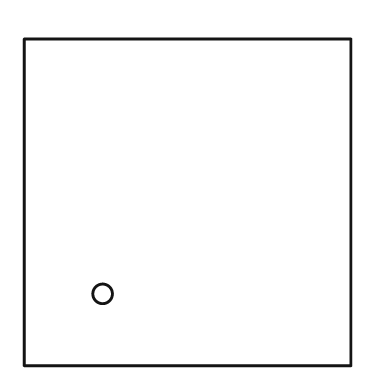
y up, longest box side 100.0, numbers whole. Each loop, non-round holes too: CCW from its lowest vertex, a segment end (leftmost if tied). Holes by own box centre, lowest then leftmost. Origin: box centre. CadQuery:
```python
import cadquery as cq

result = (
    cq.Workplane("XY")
    .moveTo(-50.0, -50.0)
    .lineTo(50.0, -50.0)
    .lineTo(50.0, 50.0)
    .lineTo(-50.0, 50.0)
    .close()
    .moveTo(-26.0, -28.0)
    .circle(3.0)
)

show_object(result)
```